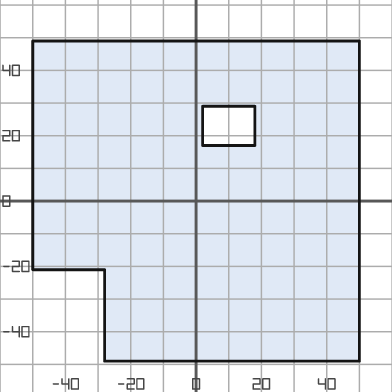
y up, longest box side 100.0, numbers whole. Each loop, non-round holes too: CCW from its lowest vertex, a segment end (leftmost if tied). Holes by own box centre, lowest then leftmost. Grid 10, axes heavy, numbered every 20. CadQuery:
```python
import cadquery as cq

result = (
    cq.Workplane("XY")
    .moveTo(-28.0, -49.0)
    .lineTo(50.0, -49.0)
    .lineTo(50.0, 49.0)
    .lineTo(-50.0, 49.0)
    .lineTo(-50.0, -21.0)
    .lineTo(-28.0, -21.0)
    .close()
    .moveTo(2.0, 17.0)
    .lineTo(18.0, 17.0)
    .lineTo(18.0, 29.0)
    .lineTo(2.0, 29.0)
    .close()
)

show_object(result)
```